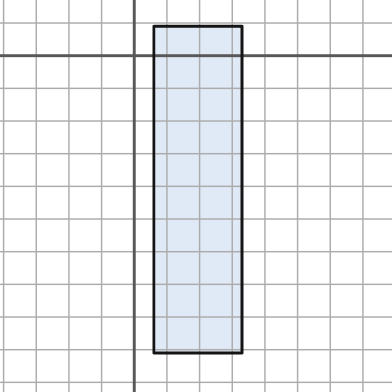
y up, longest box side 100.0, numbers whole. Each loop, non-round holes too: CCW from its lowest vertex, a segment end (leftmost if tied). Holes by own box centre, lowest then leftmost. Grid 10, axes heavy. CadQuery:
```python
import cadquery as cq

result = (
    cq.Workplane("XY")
    .moveTo(6.0, -91.0)
    .lineTo(33.0, -91.0)
    .lineTo(33.0, 9.0)
    .lineTo(6.0, 9.0)
    .close()
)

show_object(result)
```